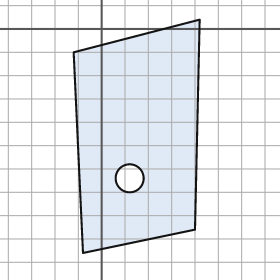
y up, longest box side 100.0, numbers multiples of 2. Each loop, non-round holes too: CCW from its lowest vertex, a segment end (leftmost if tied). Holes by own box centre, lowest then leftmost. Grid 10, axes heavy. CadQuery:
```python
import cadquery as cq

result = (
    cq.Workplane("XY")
    .moveTo(-8.0, -96.0)
    .lineTo(40.0, -86.0)
    .lineTo(42.0, 4.0)
    .lineTo(-12.0, -10.0)
    .close()
    .moveTo(12.0, -64.0)
    .circle(6.0)
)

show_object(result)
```